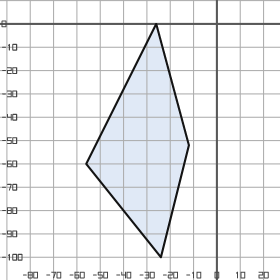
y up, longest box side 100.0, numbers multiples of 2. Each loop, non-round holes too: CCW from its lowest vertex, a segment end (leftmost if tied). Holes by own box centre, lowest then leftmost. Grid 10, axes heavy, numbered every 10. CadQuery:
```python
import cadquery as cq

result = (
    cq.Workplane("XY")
    .moveTo(-24.0, -100.0)
    .lineTo(-12.0, -52.0)
    .lineTo(-26.0, 0.0)
    .lineTo(-56.0, -60.0)
    .close()
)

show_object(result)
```